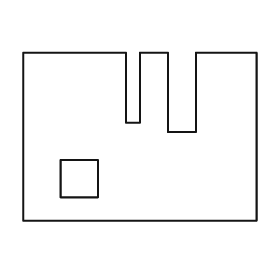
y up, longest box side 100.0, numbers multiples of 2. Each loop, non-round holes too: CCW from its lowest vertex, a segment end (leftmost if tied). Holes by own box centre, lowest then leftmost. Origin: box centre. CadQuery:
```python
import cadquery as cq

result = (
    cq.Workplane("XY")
    .moveTo(-50.0, -36.0)
    .lineTo(50.0, -36.0)
    .lineTo(50.0, 36.0)
    .lineTo(24.0, 36.0)
    .lineTo(24.0, 2.0)
    .lineTo(12.0, 2.0)
    .lineTo(12.0, 36.0)
    .lineTo(0.0, 36.0)
    .lineTo(0.0, 6.0)
    .lineTo(-6.0, 6.0)
    .lineTo(-6.0, 36.0)
    .lineTo(-50.0, 36.0)
    .close()
    .moveTo(-34.0, -26.0)
    .lineTo(-18.0, -26.0)
    .lineTo(-18.0, -10.0)
    .lineTo(-34.0, -10.0)
    .close()
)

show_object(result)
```